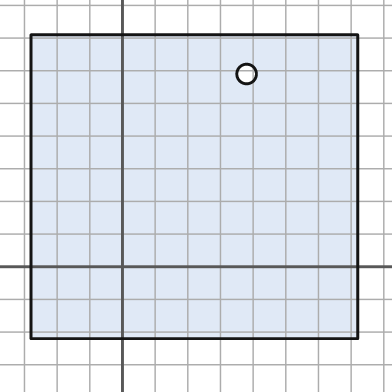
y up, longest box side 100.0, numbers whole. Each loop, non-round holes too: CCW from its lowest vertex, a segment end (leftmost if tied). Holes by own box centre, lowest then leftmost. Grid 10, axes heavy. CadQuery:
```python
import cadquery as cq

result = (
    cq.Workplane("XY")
    .moveTo(-28.0, -22.0)
    .lineTo(72.0, -22.0)
    .lineTo(72.0, 71.0)
    .lineTo(-28.0, 71.0)
    .close()
    .moveTo(38.0, 59.0)
    .circle(3.0)
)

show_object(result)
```